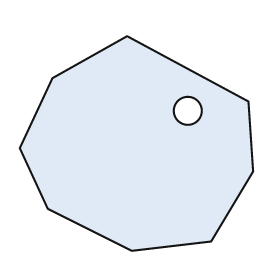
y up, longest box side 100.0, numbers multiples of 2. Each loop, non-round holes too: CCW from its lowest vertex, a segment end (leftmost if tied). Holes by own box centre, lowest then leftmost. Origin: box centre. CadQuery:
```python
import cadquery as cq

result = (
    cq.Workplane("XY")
    .moveTo(-2.0, -46.0)
    .lineTo(32.0, -42.0)
    .lineTo(50.0, -12.0)
    .lineTo(48.0, 18.0)
    .lineTo(-4.0, 46.0)
    .lineTo(-36.0, 28.0)
    .lineTo(-50.0, -2.0)
    .lineTo(-38.0, -28.0)
    .close()
    .moveTo(22.0, 14.0)
    .circle(6.0)
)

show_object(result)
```